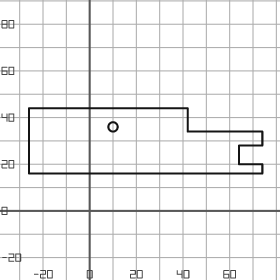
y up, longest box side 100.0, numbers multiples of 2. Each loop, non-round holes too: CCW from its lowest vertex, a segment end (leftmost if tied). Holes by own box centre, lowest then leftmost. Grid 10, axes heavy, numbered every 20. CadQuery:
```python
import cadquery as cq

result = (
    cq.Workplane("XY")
    .moveTo(-26.0, 16.0)
    .lineTo(74.0, 16.0)
    .lineTo(74.0, 20.0)
    .lineTo(64.0, 20.0)
    .lineTo(64.0, 28.0)
    .lineTo(74.0, 28.0)
    .lineTo(74.0, 34.0)
    .lineTo(42.0, 34.0)
    .lineTo(42.0, 44.0)
    .lineTo(-26.0, 44.0)
    .close()
    .moveTo(10.0, 36.0)
    .circle(2.0)
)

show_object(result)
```